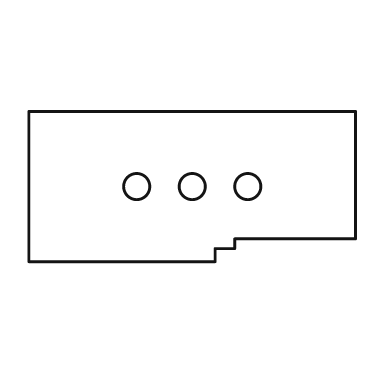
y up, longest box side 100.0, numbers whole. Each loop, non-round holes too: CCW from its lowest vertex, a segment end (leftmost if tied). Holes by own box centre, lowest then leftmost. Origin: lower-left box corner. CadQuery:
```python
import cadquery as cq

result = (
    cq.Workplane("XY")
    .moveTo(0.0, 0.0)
    .lineTo(57.0, 0.0)
    .lineTo(57.0, 4.0)
    .lineTo(63.0, 4.0)
    .lineTo(63.0, 7.0)
    .lineTo(100.0, 7.0)
    .lineTo(100.0, 46.0)
    .lineTo(0.0, 46.0)
    .close()
    .moveTo(33.0, 23.0)
    .circle(4.0)
    .moveTo(50.0, 23.0)
    .circle(4.0)
    .moveTo(67.0, 23.0)
    .circle(4.0)
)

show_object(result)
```